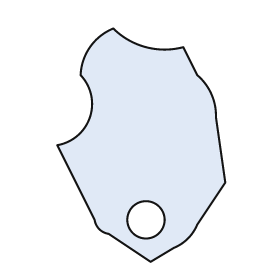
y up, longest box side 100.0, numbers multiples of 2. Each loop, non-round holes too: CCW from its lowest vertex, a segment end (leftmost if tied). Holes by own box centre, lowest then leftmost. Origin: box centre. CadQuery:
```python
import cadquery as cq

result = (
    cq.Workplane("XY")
    .moveTo(4.0, -50.0)
    .lineTo(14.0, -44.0)
    .threePointArc((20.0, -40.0), (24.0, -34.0))
    .lineTo(36.0, -16.0)
    .lineTo(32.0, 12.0)
    .threePointArc((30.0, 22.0), (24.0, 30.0))
    .lineTo(18.0, 42.0)
    .threePointArc((2.0, 42.0), (-12.0, 50.0))
    .threePointArc((-22.0, 42.0), (-26.0, 30.0))
    .threePointArc((-22.0, 12.0), (-36.0, 0.0))
    .lineTo(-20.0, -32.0)
    .threePointArc((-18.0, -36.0), (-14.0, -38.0))
    .close()
    .moveTo(2.0, -32.0)
    .circle(8.0)
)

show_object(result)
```